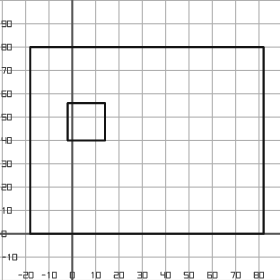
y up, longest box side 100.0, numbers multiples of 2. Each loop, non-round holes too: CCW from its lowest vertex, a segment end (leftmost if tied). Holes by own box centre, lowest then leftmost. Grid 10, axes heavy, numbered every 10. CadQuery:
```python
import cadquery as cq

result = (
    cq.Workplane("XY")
    .moveTo(-18.0, 0.0)
    .lineTo(82.0, 0.0)
    .lineTo(82.0, 80.0)
    .lineTo(-18.0, 80.0)
    .close()
    .moveTo(-2.0, 40.0)
    .lineTo(14.0, 40.0)
    .lineTo(14.0, 56.0)
    .lineTo(-2.0, 56.0)
    .close()
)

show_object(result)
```